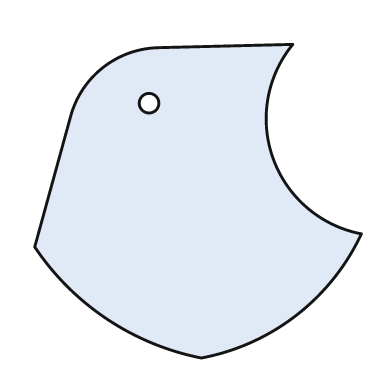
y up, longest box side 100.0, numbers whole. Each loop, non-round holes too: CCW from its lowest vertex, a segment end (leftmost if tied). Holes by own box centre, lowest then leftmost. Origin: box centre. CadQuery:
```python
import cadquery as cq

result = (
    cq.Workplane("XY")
    .moveTo(1.0, -48.0)
    .threePointArc((30.0, -35.0), (50.0, -10.0))
    .threePointArc((23.0, 13.0), (29.0, 48.0))
    .lineTo(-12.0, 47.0)
    .threePointArc((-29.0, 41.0), (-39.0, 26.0))
    .lineTo(-50.0, -14.0)
    .threePointArc((-28.0, -36.0), (1.0, -48.0))
    .close()
    .moveTo(-15.0, 30.0)
    .circle(3.0)
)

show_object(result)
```